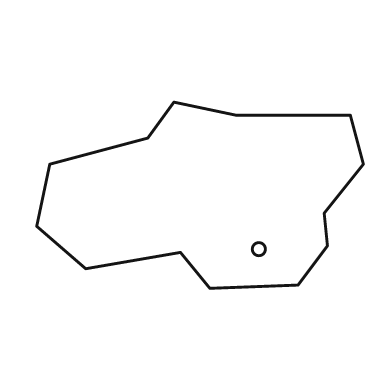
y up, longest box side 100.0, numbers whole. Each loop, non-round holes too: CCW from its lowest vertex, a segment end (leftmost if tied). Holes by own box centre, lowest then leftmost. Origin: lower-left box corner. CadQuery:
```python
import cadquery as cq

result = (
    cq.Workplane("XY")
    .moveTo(53.0, 0.0)
    .lineTo(80.0, 1.0)
    .lineTo(89.0, 13.0)
    .lineTo(88.0, 23.0)
    .lineTo(100.0, 38.0)
    .lineTo(96.0, 53.0)
    .lineTo(61.0, 53.0)
    .lineTo(42.0, 57.0)
    .lineTo(34.0, 46.0)
    .lineTo(4.0, 38.0)
    .lineTo(0.0, 19.0)
    .lineTo(15.0, 6.0)
    .lineTo(44.0, 11.0)
    .close()
    .moveTo(68.0, 12.0)
    .circle(2.0)
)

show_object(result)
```